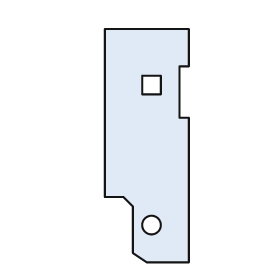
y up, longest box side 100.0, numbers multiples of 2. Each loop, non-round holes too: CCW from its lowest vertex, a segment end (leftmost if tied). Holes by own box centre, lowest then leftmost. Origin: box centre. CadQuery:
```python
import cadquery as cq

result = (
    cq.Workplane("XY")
    .moveTo(0.0, -50.0)
    .lineTo(18.0, -50.0)
    .lineTo(18.0, 12.0)
    .lineTo(14.0, 12.0)
    .lineTo(14.0, 34.0)
    .lineTo(18.0, 34.0)
    .lineTo(18.0, 50.0)
    .lineTo(-18.0, 50.0)
    .lineTo(-18.0, -22.0)
    .lineTo(-10.0, -22.0)
    .lineTo(-6.0, -26.0)
    .lineTo(-6.0, -46.0)
    .close()
    .moveTo(2.0, -34.0)
    .circle(4.0)
    .moveTo(-2.0, 22.0)
    .lineTo(6.0, 22.0)
    .lineTo(6.0, 30.0)
    .lineTo(-2.0, 30.0)
    .close()
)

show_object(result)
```